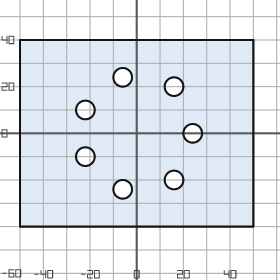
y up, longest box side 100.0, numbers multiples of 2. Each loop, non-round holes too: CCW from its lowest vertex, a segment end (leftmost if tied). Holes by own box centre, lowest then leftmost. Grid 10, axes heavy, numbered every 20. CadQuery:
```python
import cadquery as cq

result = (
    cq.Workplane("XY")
    .moveTo(-50.0, -40.0)
    .lineTo(50.0, -40.0)
    .lineTo(50.0, 40.0)
    .lineTo(-50.0, 40.0)
    .close()
    .moveTo(-6.0, -24.0)
    .circle(4.0)
    .moveTo(16.0, -20.0)
    .circle(4.0)
    .moveTo(-22.0, -10.0)
    .circle(4.0)
    .moveTo(24.0, 0.0)
    .circle(4.0)
    .moveTo(-22.0, 10.0)
    .circle(4.0)
    .moveTo(16.0, 20.0)
    .circle(4.0)
    .moveTo(-6.0, 24.0)
    .circle(4.0)
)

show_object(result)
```